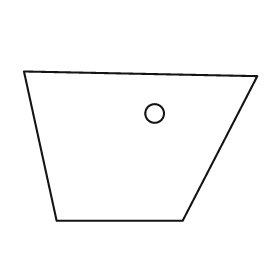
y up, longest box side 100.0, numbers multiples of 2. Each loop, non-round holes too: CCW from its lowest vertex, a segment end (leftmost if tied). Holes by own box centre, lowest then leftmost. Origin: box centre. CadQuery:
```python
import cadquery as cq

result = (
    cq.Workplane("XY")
    .moveTo(-36.0, -32.0)
    .lineTo(18.0, -32.0)
    .lineTo(50.0, 30.0)
    .lineTo(-50.0, 32.0)
    .close()
    .moveTo(6.0, 14.0)
    .circle(4.0)
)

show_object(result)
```